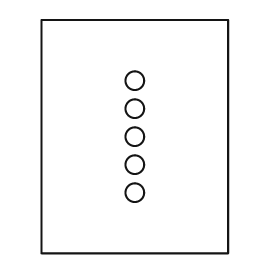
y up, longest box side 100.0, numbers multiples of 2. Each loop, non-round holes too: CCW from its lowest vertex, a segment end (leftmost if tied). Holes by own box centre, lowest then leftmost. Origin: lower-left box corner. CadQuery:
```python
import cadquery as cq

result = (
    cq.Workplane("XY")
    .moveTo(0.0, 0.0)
    .lineTo(80.0, 0.0)
    .lineTo(80.0, 100.0)
    .lineTo(0.0, 100.0)
    .close()
    .moveTo(40.0, 26.0)
    .circle(4.0)
    .moveTo(40.0, 38.0)
    .circle(4.0)
    .moveTo(40.0, 50.0)
    .circle(4.0)
    .moveTo(40.0, 62.0)
    .circle(4.0)
    .moveTo(40.0, 74.0)
    .circle(4.0)
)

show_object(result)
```